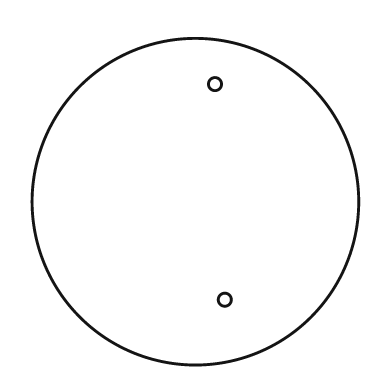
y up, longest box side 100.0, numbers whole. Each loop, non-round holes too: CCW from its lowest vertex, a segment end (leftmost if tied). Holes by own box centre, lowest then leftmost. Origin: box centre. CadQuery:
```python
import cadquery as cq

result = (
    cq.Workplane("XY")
    .moveTo(0.0, 0.0)
    .circle(50.0)
    .moveTo(9.0, -30.0)
    .circle(2.0)
    .moveTo(6.0, 36.0)
    .circle(2.0)
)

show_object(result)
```